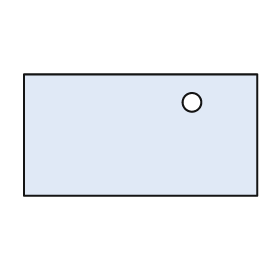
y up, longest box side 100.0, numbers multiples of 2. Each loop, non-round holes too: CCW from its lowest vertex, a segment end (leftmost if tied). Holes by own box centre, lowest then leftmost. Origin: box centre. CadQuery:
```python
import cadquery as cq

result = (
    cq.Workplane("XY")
    .moveTo(-50.0, -26.0)
    .lineTo(50.0, -26.0)
    .lineTo(50.0, 26.0)
    .lineTo(-50.0, 26.0)
    .close()
    .moveTo(22.0, 14.0)
    .circle(4.0)
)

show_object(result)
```